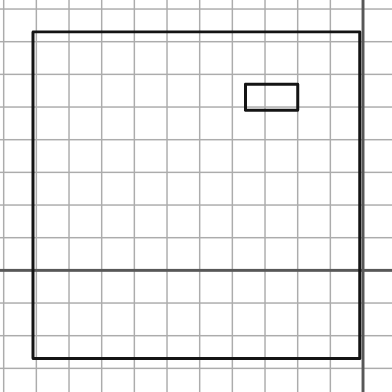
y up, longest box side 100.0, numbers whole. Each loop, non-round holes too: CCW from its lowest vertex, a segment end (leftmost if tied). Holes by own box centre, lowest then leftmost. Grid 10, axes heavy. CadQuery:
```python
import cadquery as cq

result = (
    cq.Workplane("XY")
    .moveTo(-101.0, -27.0)
    .lineTo(-1.0, -27.0)
    .lineTo(-1.0, 73.0)
    .lineTo(-101.0, 73.0)
    .close()
    .moveTo(-36.0, 49.0)
    .lineTo(-20.0, 49.0)
    .lineTo(-20.0, 57.0)
    .lineTo(-36.0, 57.0)
    .close()
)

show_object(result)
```